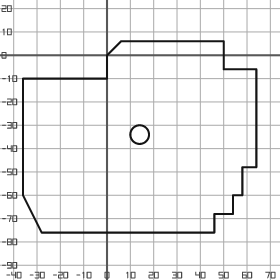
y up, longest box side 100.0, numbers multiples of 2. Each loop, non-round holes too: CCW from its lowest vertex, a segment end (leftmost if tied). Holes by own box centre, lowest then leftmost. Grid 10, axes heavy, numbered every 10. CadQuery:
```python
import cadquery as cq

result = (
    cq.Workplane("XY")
    .moveTo(-28.0, -76.0)
    .lineTo(46.0, -76.0)
    .lineTo(46.0, -68.0)
    .lineTo(54.0, -68.0)
    .lineTo(54.0, -60.0)
    .lineTo(58.0, -60.0)
    .lineTo(58.0, -48.0)
    .lineTo(64.0, -48.0)
    .lineTo(64.0, -6.0)
    .lineTo(50.0, -6.0)
    .lineTo(50.0, 6.0)
    .lineTo(6.0, 6.0)
    .lineTo(0.0, 0.0)
    .lineTo(0.0, -10.0)
    .lineTo(-36.0, -10.0)
    .lineTo(-36.0, -60.0)
    .close()
    .moveTo(14.0, -34.0)
    .circle(4.0)
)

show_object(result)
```